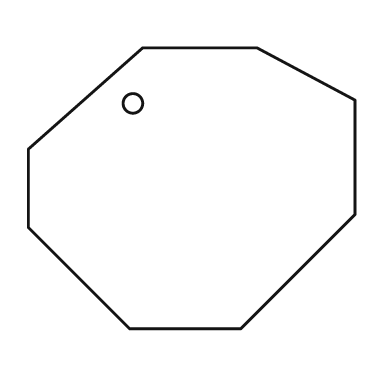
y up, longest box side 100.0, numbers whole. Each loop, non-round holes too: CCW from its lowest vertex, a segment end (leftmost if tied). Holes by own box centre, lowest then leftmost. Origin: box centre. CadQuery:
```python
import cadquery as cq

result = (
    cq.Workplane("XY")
    .moveTo(-19.0, -43.0)
    .lineTo(15.0, -43.0)
    .lineTo(50.0, -8.0)
    .lineTo(50.0, 27.0)
    .lineTo(20.0, 43.0)
    .lineTo(-15.0, 43.0)
    .lineTo(-50.0, 12.0)
    .lineTo(-50.0, -12.0)
    .close()
    .moveTo(-18.0, 26.0)
    .circle(3.0)
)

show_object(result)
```